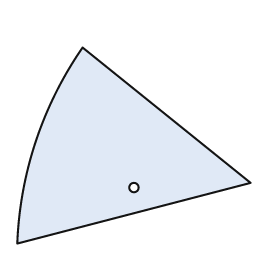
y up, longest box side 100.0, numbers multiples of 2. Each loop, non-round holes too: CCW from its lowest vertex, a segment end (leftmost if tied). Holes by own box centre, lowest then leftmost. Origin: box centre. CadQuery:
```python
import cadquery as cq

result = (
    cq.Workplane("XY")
    .moveTo(-50.0, -42.0)
    .lineTo(50.0, -16.0)
    .lineTo(-22.0, 42.0)
    .threePointArc((-42.0, 2.0), (-50.0, -42.0))
    .close()
    .moveTo(0.0, -18.0)
    .circle(2.0)
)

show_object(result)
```